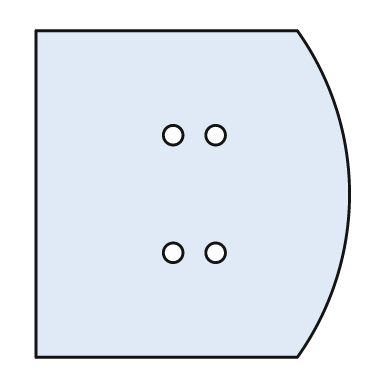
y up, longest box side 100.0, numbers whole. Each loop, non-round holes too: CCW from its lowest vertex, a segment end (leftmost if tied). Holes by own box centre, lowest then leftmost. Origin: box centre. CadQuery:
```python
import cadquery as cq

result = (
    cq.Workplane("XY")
    .moveTo(-48.0, -50.0)
    .lineTo(32.0, -50.0)
    .threePointArc((48.0, 0.0), (32.0, 50.0))
    .lineTo(-48.0, 50.0)
    .close()
    .moveTo(-6.0, -18.0)
    .circle(3.0)
    .moveTo(7.0, -18.0)
    .circle(3.0)
    .moveTo(-6.0, 18.0)
    .circle(3.0)
    .moveTo(7.0, 18.0)
    .circle(3.0)
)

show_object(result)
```